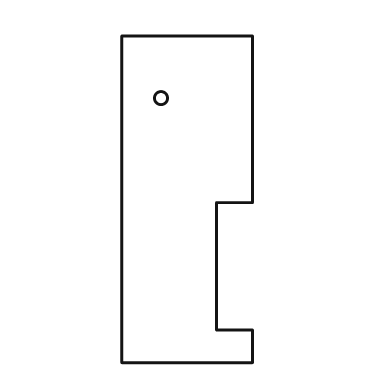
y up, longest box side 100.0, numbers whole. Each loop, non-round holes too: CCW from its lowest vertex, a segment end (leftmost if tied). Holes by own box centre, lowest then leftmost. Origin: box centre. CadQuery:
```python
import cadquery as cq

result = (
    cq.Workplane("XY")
    .moveTo(-20.0, -50.0)
    .lineTo(20.0, -50.0)
    .lineTo(20.0, -40.0)
    .lineTo(9.0, -40.0)
    .lineTo(9.0, -1.0)
    .lineTo(20.0, -1.0)
    .lineTo(20.0, 50.0)
    .lineTo(-20.0, 50.0)
    .close()
    .moveTo(-8.0, 31.0)
    .circle(2.0)
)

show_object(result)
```